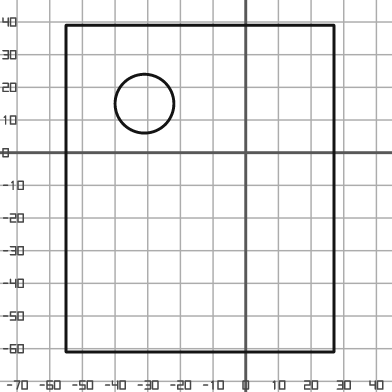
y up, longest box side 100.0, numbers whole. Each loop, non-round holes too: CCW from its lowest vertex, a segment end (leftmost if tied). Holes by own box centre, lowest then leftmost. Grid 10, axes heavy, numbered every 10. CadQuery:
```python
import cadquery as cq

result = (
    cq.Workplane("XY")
    .moveTo(-55.0, -61.0)
    .lineTo(27.0, -61.0)
    .lineTo(27.0, 39.0)
    .lineTo(-55.0, 39.0)
    .close()
    .moveTo(-31.0, 15.0)
    .circle(9.0)
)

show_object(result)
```